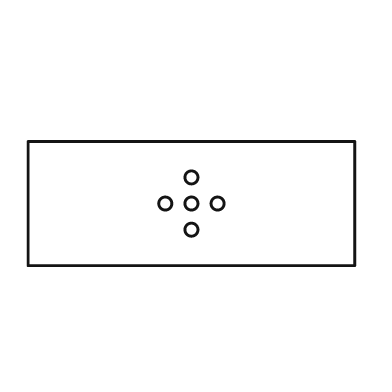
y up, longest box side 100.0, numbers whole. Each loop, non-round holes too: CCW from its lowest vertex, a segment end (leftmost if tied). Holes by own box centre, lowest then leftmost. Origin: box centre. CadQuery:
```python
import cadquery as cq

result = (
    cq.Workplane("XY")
    .moveTo(-50.0, -19.0)
    .lineTo(50.0, -19.0)
    .lineTo(50.0, 19.0)
    .lineTo(-50.0, 19.0)
    .close()
    .moveTo(0.0, -8.0)
    .circle(2.0)
    .moveTo(-8.0, 0.0)
    .circle(2.0)
    .moveTo(0.0, 0.0)
    .circle(2.0)
    .moveTo(8.0, 0.0)
    .circle(2.0)
    .moveTo(0.0, 8.0)
    .circle(2.0)
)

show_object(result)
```